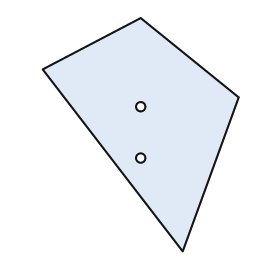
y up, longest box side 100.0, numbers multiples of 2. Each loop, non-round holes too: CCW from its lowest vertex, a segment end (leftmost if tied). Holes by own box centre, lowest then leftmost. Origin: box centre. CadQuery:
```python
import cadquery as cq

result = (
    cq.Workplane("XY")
    .moveTo(18.0, -50.0)
    .lineTo(42.0, 16.0)
    .lineTo(0.0, 50.0)
    .lineTo(-42.0, 28.0)
    .close()
    .moveTo(0.0, -10.0)
    .circle(2.0)
    .moveTo(0.0, 12.0)
    .circle(2.0)
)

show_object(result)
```